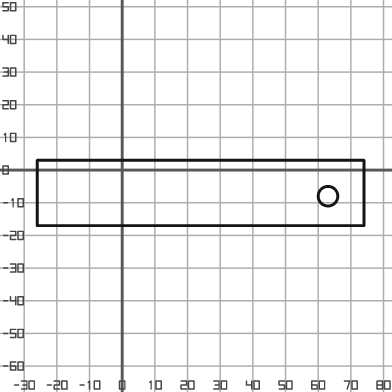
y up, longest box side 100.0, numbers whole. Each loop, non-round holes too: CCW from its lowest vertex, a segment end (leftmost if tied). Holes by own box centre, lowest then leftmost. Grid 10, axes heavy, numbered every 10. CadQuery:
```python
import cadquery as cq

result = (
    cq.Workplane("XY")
    .moveTo(-26.0, -17.0)
    .lineTo(74.0, -17.0)
    .lineTo(74.0, 3.0)
    .lineTo(-26.0, 3.0)
    .close()
    .moveTo(63.0, -8.0)
    .circle(3.0)
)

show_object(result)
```